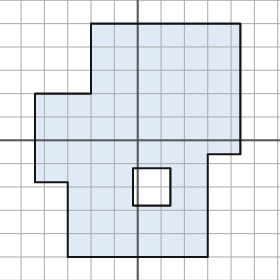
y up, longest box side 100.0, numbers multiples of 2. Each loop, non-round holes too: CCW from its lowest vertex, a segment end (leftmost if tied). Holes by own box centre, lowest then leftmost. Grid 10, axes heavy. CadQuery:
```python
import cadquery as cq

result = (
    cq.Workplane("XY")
    .moveTo(-30.0, -50.0)
    .lineTo(30.0, -50.0)
    .lineTo(30.0, -6.0)
    .lineTo(44.0, -6.0)
    .lineTo(44.0, 50.0)
    .lineTo(-20.0, 50.0)
    .lineTo(-20.0, 20.0)
    .lineTo(-44.0, 20.0)
    .lineTo(-44.0, -18.0)
    .lineTo(-30.0, -18.0)
    .close()
    .moveTo(-2.0, -28.0)
    .lineTo(14.0, -28.0)
    .lineTo(14.0, -12.0)
    .lineTo(-2.0, -12.0)
    .close()
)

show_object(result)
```